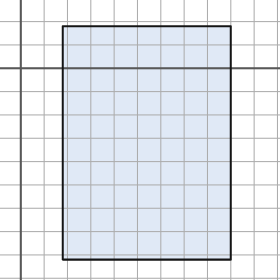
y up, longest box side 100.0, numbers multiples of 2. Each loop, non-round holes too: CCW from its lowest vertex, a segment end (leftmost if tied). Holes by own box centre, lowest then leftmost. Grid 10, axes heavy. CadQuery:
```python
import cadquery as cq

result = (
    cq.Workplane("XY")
    .moveTo(18.0, -82.0)
    .lineTo(90.0, -82.0)
    .lineTo(90.0, 18.0)
    .lineTo(18.0, 18.0)
    .close()
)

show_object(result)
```